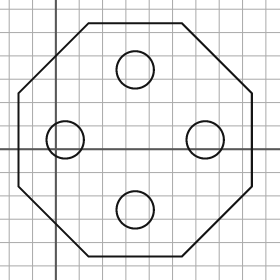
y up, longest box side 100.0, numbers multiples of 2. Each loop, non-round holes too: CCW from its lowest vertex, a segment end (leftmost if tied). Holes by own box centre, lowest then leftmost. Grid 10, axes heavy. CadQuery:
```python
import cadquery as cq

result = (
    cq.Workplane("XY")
    .moveTo(14.0, -46.0)
    .lineTo(54.0, -46.0)
    .lineTo(84.0, -16.0)
    .lineTo(84.0, 24.0)
    .lineTo(54.0, 54.0)
    .lineTo(14.0, 54.0)
    .lineTo(-16.0, 24.0)
    .lineTo(-16.0, -16.0)
    .close()
    .moveTo(34.0, -26.0)
    .circle(8.0)
    .moveTo(4.0, 4.0)
    .circle(8.0)
    .moveTo(64.0, 4.0)
    .circle(8.0)
    .moveTo(34.0, 34.0)
    .circle(8.0)
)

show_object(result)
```